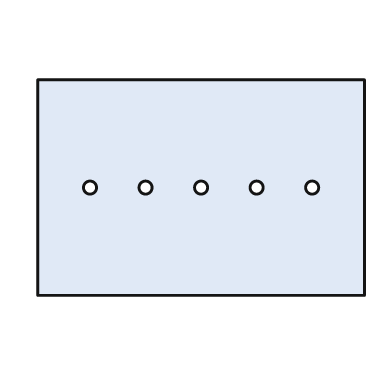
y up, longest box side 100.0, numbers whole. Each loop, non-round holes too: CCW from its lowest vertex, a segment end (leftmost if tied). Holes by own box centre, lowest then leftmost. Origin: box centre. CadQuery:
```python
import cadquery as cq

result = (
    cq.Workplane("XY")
    .moveTo(-50.0, -33.0)
    .lineTo(50.0, -33.0)
    .lineTo(50.0, 33.0)
    .lineTo(-50.0, 33.0)
    .close()
    .moveTo(-34.0, 0.0)
    .circle(2.0)
    .moveTo(-17.0, 0.0)
    .circle(2.0)
    .moveTo(0.0, 0.0)
    .circle(2.0)
    .moveTo(17.0, 0.0)
    .circle(2.0)
    .moveTo(34.0, 0.0)
    .circle(2.0)
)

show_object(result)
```